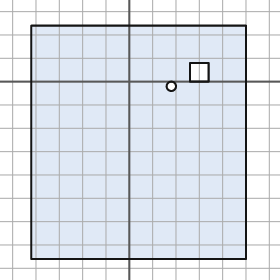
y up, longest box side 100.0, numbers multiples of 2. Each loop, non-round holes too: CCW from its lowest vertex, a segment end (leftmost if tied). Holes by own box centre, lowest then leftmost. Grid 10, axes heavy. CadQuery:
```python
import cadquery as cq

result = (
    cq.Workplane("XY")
    .moveTo(-42.0, -76.0)
    .lineTo(50.0, -76.0)
    .lineTo(50.0, 24.0)
    .lineTo(-42.0, 24.0)
    .close()
    .moveTo(18.0, -2.0)
    .circle(2.0)
    .moveTo(26.0, 0.0)
    .lineTo(34.0, 0.0)
    .lineTo(34.0, 8.0)
    .lineTo(26.0, 8.0)
    .close()
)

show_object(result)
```